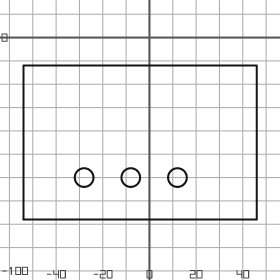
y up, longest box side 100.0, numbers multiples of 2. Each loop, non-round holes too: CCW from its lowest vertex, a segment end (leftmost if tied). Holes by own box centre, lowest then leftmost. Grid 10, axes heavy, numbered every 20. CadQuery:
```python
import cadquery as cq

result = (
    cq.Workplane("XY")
    .moveTo(-54.0, -78.0)
    .lineTo(46.0, -78.0)
    .lineTo(46.0, -12.0)
    .lineTo(-54.0, -12.0)
    .close()
    .moveTo(-28.0, -60.0)
    .circle(4.0)
    .moveTo(-8.0, -60.0)
    .circle(4.0)
    .moveTo(12.0, -60.0)
    .circle(4.0)
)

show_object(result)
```